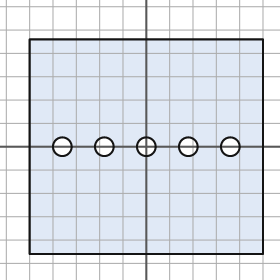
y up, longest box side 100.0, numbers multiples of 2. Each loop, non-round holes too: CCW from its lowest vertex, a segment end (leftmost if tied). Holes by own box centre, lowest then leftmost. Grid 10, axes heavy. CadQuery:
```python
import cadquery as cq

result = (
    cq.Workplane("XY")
    .moveTo(-50.0, -46.0)
    .lineTo(50.0, -46.0)
    .lineTo(50.0, 46.0)
    .lineTo(-50.0, 46.0)
    .close()
    .moveTo(-36.0, 0.0)
    .circle(4.0)
    .moveTo(-18.0, 0.0)
    .circle(4.0)
    .moveTo(0.0, 0.0)
    .circle(4.0)
    .moveTo(18.0, 0.0)
    .circle(4.0)
    .moveTo(36.0, 0.0)
    .circle(4.0)
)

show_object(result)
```